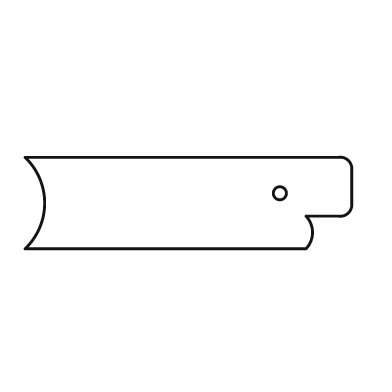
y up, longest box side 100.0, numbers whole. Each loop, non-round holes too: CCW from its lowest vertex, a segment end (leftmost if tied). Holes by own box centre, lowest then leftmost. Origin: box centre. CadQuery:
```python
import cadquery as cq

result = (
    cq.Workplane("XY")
    .moveTo(-50.0, -14.0)
    .lineTo(36.0, -14.0)
    .threePointArc((38.0, -9.0), (36.0, -4.0))
    .lineTo(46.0, -4.0)
    .threePointArc((49.0, -3.0), (50.0, 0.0))
    .lineTo(50.0, 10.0)
    .threePointArc((49.0, 13.0), (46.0, 14.0))
    .lineTo(-50.0, 14.0)
    .threePointArc((-44.0, 0.0), (-50.0, -14.0))
    .close()
    .moveTo(28.0, 3.0)
    .circle(2.0)
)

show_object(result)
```